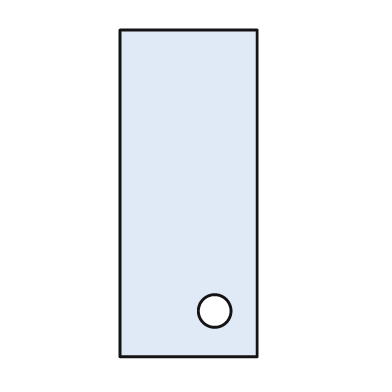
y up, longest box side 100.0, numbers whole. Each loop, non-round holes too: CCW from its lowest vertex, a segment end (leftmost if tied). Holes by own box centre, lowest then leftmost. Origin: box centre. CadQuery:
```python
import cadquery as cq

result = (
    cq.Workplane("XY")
    .moveTo(-21.0, -50.0)
    .lineTo(21.0, -50.0)
    .lineTo(21.0, 50.0)
    .lineTo(-21.0, 50.0)
    .close()
    .moveTo(8.0, -36.0)
    .circle(5.0)
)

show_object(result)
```